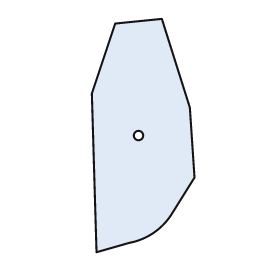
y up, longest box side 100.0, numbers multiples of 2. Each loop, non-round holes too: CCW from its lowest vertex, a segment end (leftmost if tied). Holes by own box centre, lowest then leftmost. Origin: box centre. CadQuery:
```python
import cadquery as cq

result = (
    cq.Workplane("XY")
    .moveTo(-20.0, -50.0)
    .lineTo(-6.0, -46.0)
    .threePointArc((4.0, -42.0), (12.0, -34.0))
    .lineTo(22.0, -18.0)
    .lineTo(20.0, 12.0)
    .lineTo(8.0, 50.0)
    .lineTo(-12.0, 48.0)
    .lineTo(-22.0, 18.0)
    .close()
    .moveTo(-2.0, 0.0)
    .circle(2.0)
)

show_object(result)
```